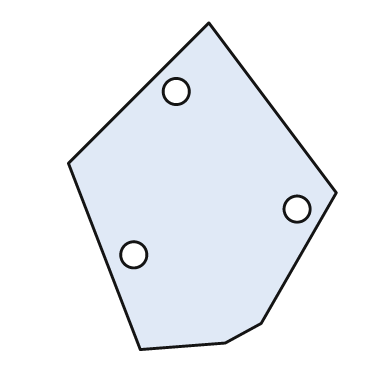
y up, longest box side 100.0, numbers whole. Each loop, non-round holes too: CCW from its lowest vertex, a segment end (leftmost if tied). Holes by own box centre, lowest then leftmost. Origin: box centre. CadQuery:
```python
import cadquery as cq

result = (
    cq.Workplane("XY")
    .moveTo(-19.0, -50.0)
    .lineTo(7.0, -48.0)
    .lineTo(18.0, -42.0)
    .lineTo(41.0, -2.0)
    .lineTo(2.0, 50.0)
    .lineTo(-41.0, 7.0)
    .close()
    .moveTo(-21.0, -21.0)
    .circle(4.0)
    .moveTo(29.0, -7.0)
    .circle(4.0)
    .moveTo(-8.0, 29.0)
    .circle(4.0)
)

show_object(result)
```